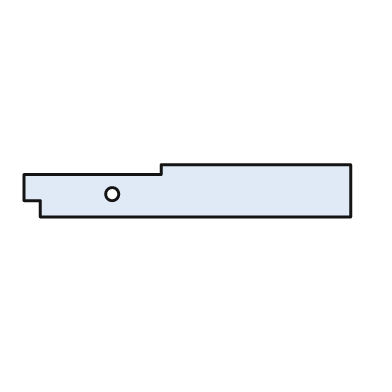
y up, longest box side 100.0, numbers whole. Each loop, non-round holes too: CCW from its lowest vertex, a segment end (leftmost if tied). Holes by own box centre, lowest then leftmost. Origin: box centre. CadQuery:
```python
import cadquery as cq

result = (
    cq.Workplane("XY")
    .moveTo(-45.0, -8.0)
    .lineTo(50.0, -8.0)
    .lineTo(50.0, 8.0)
    .lineTo(-8.0, 8.0)
    .lineTo(-8.0, 5.0)
    .lineTo(-50.0, 5.0)
    .lineTo(-50.0, -3.0)
    .lineTo(-45.0, -3.0)
    .close()
    .moveTo(-23.0, -1.0)
    .circle(2.0)
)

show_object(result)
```